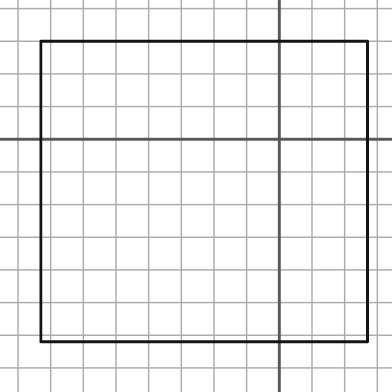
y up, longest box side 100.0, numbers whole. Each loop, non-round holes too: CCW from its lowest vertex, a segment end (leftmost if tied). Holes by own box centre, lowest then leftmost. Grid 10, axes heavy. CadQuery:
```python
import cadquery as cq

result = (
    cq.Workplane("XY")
    .moveTo(-73.0, -62.0)
    .lineTo(27.0, -62.0)
    .lineTo(27.0, 30.0)
    .lineTo(-73.0, 30.0)
    .close()
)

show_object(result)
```